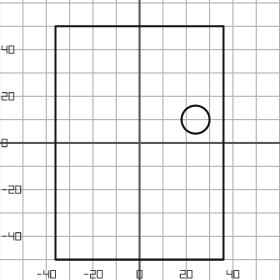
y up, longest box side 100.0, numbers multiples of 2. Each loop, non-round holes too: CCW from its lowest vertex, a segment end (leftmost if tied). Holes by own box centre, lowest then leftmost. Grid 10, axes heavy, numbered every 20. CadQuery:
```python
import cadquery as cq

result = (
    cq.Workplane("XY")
    .moveTo(-36.0, -50.0)
    .lineTo(36.0, -50.0)
    .lineTo(36.0, 50.0)
    .lineTo(-36.0, 50.0)
    .close()
    .moveTo(24.0, 10.0)
    .circle(6.0)
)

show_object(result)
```